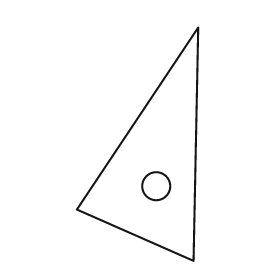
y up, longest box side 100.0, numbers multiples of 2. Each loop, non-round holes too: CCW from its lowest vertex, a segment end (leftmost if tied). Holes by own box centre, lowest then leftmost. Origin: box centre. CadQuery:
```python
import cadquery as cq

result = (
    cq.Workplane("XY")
    .moveTo(24.0, -50.0)
    .lineTo(26.0, 50.0)
    .lineTo(-26.0, -28.0)
    .close()
    .moveTo(8.0, -18.0)
    .circle(6.0)
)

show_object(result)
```